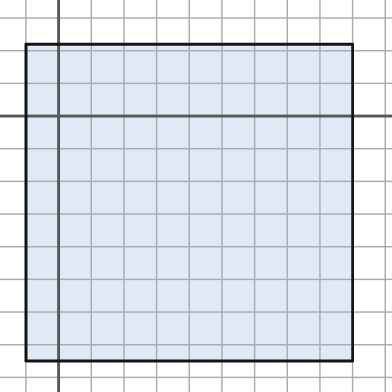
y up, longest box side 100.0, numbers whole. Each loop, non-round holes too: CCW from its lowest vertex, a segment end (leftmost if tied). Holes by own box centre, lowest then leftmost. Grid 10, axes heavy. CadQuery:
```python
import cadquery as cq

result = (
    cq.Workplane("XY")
    .moveTo(-10.0, -75.0)
    .lineTo(90.0, -75.0)
    .lineTo(90.0, 22.0)
    .lineTo(-10.0, 22.0)
    .close()
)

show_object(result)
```